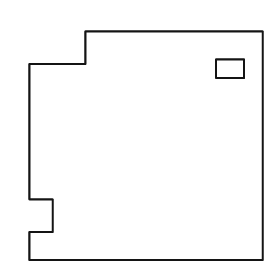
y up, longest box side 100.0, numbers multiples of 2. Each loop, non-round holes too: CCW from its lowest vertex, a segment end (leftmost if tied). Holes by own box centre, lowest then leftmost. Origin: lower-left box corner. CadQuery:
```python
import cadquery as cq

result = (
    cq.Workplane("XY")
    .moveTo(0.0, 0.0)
    .lineTo(100.0, 0.0)
    .lineTo(100.0, 98.0)
    .lineTo(24.0, 98.0)
    .lineTo(24.0, 84.0)
    .lineTo(0.0, 84.0)
    .lineTo(0.0, 26.0)
    .lineTo(10.0, 26.0)
    .lineTo(10.0, 12.0)
    .lineTo(0.0, 12.0)
    .close()
    .moveTo(80.0, 78.0)
    .lineTo(92.0, 78.0)
    .lineTo(92.0, 86.0)
    .lineTo(80.0, 86.0)
    .close()
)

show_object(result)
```